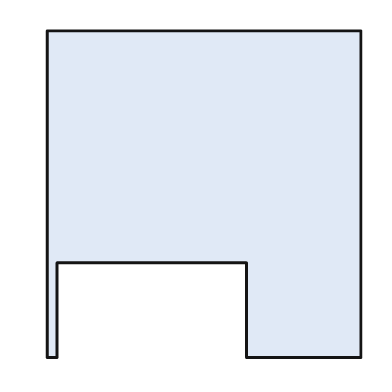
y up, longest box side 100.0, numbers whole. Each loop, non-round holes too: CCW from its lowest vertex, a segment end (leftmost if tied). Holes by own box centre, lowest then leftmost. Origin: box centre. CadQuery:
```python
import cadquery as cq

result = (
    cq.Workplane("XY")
    .moveTo(-48.0, -50.0)
    .lineTo(-45.0, -50.0)
    .lineTo(-45.0, -21.0)
    .lineTo(13.0, -21.0)
    .lineTo(13.0, -50.0)
    .lineTo(48.0, -50.0)
    .lineTo(48.0, 50.0)
    .lineTo(-48.0, 50.0)
    .close()
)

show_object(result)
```